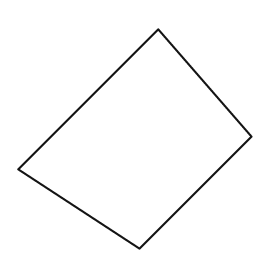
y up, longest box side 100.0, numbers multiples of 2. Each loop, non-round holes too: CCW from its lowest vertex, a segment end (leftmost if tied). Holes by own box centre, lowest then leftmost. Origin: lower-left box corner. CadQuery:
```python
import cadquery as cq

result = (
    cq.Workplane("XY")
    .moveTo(52.0, 0.0)
    .lineTo(100.0, 48.0)
    .lineTo(60.0, 94.0)
    .lineTo(0.0, 34.0)
    .close()
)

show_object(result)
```